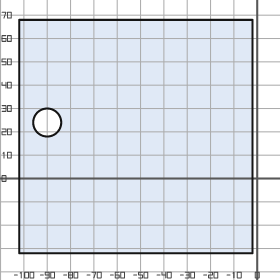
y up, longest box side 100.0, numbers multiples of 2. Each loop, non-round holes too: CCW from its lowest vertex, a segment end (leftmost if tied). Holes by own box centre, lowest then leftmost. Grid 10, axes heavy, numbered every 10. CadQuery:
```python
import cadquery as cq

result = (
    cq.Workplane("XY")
    .moveTo(-102.0, -32.0)
    .lineTo(-2.0, -32.0)
    .lineTo(-2.0, 68.0)
    .lineTo(-102.0, 68.0)
    .close()
    .moveTo(-90.0, 24.0)
    .circle(6.0)
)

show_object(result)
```